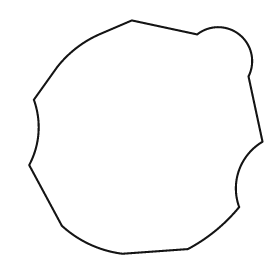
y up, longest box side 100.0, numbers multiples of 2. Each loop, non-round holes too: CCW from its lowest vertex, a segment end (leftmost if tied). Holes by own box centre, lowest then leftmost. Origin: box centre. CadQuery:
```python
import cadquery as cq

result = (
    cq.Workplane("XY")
    .moveTo(-10.0, -50.0)
    .lineTo(18.0, -48.0)
    .threePointArc((30.0, -40.0), (40.0, -30.0))
    .threePointArc((40.0, -14.0), (50.0, -2.0))
    .lineTo(44.0, 26.0)
    .threePointArc((40.0, 44.0), (22.0, 44.0))
    .lineTo(-6.0, 50.0)
    .lineTo(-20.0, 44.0)
    .threePointArc((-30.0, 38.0), (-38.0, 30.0))
    .lineTo(-48.0, 16.0)
    .threePointArc((-46.0, 2.0), (-50.0, -12.0))
    .lineTo(-36.0, -38.0)
    .threePointArc((-24.0, -46.0), (-10.0, -50.0))
    .close()
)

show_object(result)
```